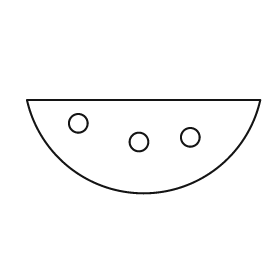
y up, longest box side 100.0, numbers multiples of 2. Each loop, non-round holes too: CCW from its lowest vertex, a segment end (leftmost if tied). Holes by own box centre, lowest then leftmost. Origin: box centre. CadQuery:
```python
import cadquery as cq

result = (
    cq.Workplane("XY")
    .moveTo(-50.0, 20.0)
    .threePointArc((0.0, -20.0), (50.0, 20.0))
    .close()
    .moveTo(-2.0, 2.0)
    .circle(4.0)
    .moveTo(20.0, 4.0)
    .circle(4.0)
    .moveTo(-28.0, 10.0)
    .circle(4.0)
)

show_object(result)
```